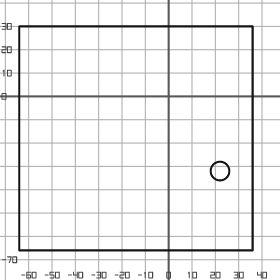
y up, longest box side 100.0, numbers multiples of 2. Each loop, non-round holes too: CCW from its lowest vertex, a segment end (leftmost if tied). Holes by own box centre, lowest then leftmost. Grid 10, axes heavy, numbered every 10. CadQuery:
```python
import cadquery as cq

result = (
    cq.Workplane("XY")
    .moveTo(-64.0, -66.0)
    .lineTo(36.0, -66.0)
    .lineTo(36.0, 30.0)
    .lineTo(-64.0, 30.0)
    .close()
    .moveTo(22.0, -32.0)
    .circle(4.0)
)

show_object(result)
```